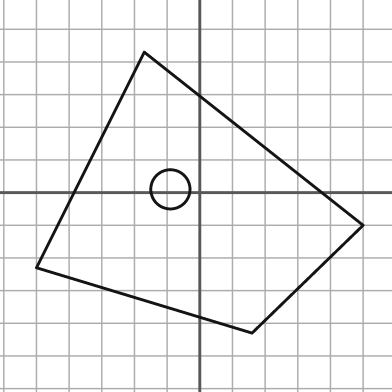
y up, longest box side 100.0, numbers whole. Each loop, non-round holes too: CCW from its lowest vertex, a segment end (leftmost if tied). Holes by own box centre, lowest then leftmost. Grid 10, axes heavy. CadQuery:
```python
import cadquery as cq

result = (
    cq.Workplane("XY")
    .moveTo(16.0, -43.0)
    .lineTo(50.0, -10.0)
    .lineTo(-17.0, 43.0)
    .lineTo(-50.0, -23.0)
    .close()
    .moveTo(-9.0, 1.0)
    .circle(6.0)
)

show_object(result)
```